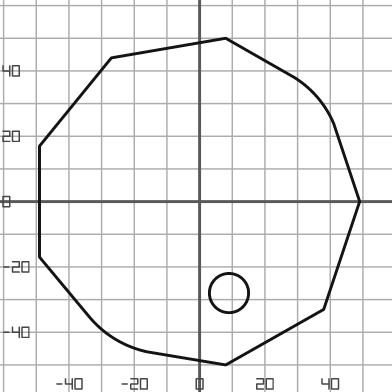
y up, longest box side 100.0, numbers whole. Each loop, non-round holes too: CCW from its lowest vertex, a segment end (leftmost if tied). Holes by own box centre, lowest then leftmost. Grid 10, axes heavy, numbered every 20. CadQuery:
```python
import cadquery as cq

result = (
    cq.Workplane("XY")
    .moveTo(8.0, -50.0)
    .lineTo(38.0, -33.0)
    .lineTo(49.0, 0.0)
    .lineTo(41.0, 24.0)
    .threePointArc((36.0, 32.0), (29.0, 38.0))
    .lineTo(8.0, 50.0)
    .lineTo(-27.0, 44.0)
    .lineTo(-49.0, 17.0)
    .lineTo(-49.0, -17.0)
    .lineTo(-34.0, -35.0)
    .threePointArc((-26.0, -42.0), (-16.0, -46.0))
    .close()
    .moveTo(9.0, -28.0)
    .circle(6.0)
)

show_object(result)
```